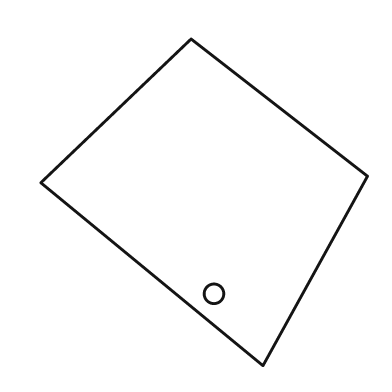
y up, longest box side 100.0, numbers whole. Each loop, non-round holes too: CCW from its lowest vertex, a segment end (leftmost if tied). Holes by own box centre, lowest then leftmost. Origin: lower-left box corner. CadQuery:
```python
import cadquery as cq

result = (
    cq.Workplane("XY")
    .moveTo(68.0, 0.0)
    .lineTo(100.0, 58.0)
    .lineTo(46.0, 100.0)
    .lineTo(0.0, 56.0)
    .close()
    .moveTo(53.0, 22.0)
    .circle(3.0)
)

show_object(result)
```